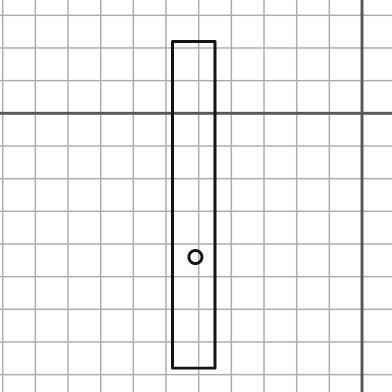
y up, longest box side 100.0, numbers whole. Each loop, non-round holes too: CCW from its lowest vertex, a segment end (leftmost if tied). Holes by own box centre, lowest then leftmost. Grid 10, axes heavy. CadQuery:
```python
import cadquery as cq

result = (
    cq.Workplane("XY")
    .moveTo(-58.0, -78.0)
    .lineTo(-45.0, -78.0)
    .lineTo(-45.0, 22.0)
    .lineTo(-58.0, 22.0)
    .close()
    .moveTo(-51.0, -44.0)
    .circle(2.0)
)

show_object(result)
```